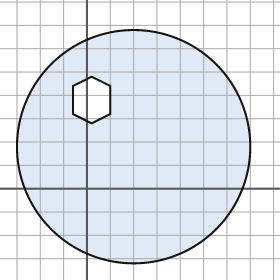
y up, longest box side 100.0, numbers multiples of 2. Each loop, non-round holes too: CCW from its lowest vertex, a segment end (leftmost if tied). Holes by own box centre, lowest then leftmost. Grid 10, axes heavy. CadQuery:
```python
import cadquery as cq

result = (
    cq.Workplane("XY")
    .moveTo(20.0, 18.0)
    .circle(50.0)
    .moveTo(2.0, 28.0)
    .lineTo(10.0, 32.0)
    .lineTo(10.0, 44.0)
    .lineTo(2.0, 48.0)
    .lineTo(-6.0, 44.0)
    .lineTo(-6.0, 32.0)
    .close()
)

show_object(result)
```